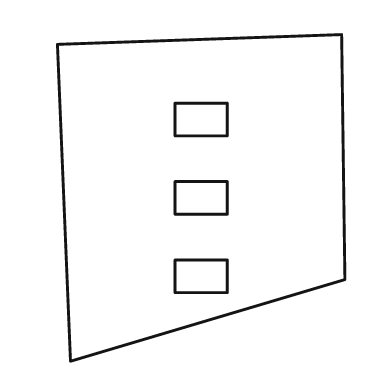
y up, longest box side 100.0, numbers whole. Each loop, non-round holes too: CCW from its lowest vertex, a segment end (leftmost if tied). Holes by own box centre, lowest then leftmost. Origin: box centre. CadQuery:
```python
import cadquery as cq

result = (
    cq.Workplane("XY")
    .moveTo(-40.0, -50.0)
    .lineTo(44.0, -25.0)
    .lineTo(43.0, 50.0)
    .lineTo(-44.0, 47.0)
    .close()
    .moveTo(-8.0, -29.0)
    .lineTo(8.0, -29.0)
    .lineTo(8.0, -19.0)
    .lineTo(-8.0, -19.0)
    .close()
    .moveTo(-8.0, -5.0)
    .lineTo(8.0, -5.0)
    .lineTo(8.0, 5.0)
    .lineTo(-8.0, 5.0)
    .close()
    .moveTo(-8.0, 19.0)
    .lineTo(8.0, 19.0)
    .lineTo(8.0, 29.0)
    .lineTo(-8.0, 29.0)
    .close()
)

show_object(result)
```